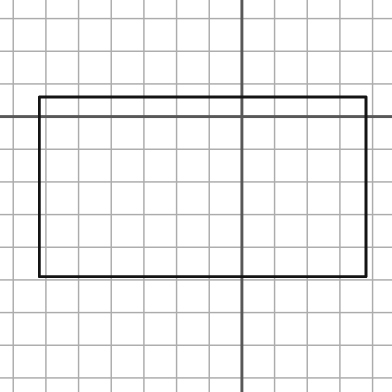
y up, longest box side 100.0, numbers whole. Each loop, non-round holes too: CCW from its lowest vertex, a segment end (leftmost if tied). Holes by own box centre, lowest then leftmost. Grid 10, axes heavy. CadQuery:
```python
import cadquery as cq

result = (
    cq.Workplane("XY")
    .moveTo(-62.0, -49.0)
    .lineTo(38.0, -49.0)
    .lineTo(38.0, 6.0)
    .lineTo(-62.0, 6.0)
    .close()
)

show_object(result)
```